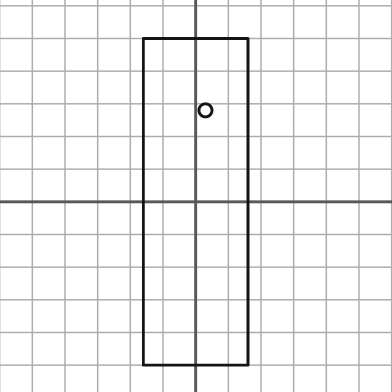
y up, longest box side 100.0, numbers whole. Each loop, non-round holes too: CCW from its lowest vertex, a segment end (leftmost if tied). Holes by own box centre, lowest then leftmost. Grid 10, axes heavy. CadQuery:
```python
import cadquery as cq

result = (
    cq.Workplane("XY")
    .moveTo(-16.0, -50.0)
    .lineTo(16.0, -50.0)
    .lineTo(16.0, 50.0)
    .lineTo(-16.0, 50.0)
    .close()
    .moveTo(3.0, 28.0)
    .circle(2.0)
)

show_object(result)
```